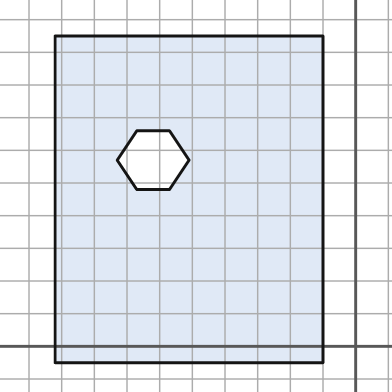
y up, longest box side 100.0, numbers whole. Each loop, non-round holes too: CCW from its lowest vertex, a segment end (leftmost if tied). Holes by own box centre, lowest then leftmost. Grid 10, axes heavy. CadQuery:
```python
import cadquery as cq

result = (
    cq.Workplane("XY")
    .moveTo(-92.0, -5.0)
    .lineTo(-10.0, -5.0)
    .lineTo(-10.0, 95.0)
    .lineTo(-92.0, 95.0)
    .close()
    .moveTo(-67.0, 48.0)
    .lineTo(-57.0, 48.0)
    .lineTo(-51.0, 57.0)
    .lineTo(-57.0, 66.0)
    .lineTo(-67.0, 66.0)
    .lineTo(-73.0, 57.0)
    .close()
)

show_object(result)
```